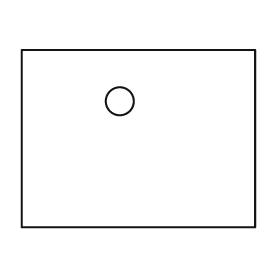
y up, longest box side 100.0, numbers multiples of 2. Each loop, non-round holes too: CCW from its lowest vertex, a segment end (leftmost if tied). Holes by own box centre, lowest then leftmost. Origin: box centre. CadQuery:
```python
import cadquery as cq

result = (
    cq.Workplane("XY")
    .moveTo(-50.0, -38.0)
    .lineTo(50.0, -38.0)
    .lineTo(50.0, 38.0)
    .lineTo(-50.0, 38.0)
    .close()
    .moveTo(-8.0, 16.0)
    .circle(6.0)
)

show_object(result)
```